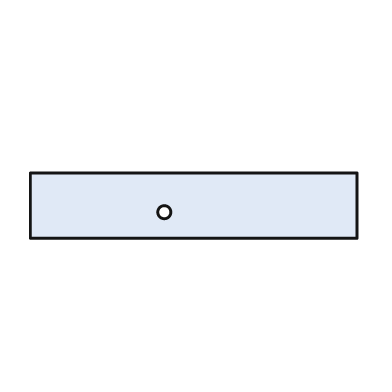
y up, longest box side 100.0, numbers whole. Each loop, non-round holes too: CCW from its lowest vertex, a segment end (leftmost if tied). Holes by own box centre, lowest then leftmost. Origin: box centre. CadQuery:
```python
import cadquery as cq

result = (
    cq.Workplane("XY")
    .moveTo(-50.0, -10.0)
    .lineTo(50.0, -10.0)
    .lineTo(50.0, 10.0)
    .lineTo(-50.0, 10.0)
    .close()
    .moveTo(-9.0, -2.0)
    .circle(2.0)
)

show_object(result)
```